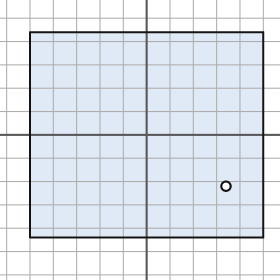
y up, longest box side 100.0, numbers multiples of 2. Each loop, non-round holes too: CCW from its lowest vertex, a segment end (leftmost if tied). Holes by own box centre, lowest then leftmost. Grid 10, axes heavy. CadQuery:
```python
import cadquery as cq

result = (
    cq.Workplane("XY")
    .moveTo(-50.0, -44.0)
    .lineTo(50.0, -44.0)
    .lineTo(50.0, 44.0)
    .lineTo(-50.0, 44.0)
    .close()
    .moveTo(34.0, -22.0)
    .circle(2.0)
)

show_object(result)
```